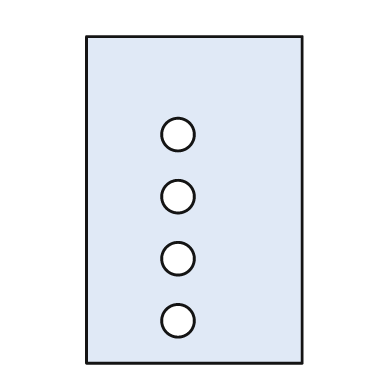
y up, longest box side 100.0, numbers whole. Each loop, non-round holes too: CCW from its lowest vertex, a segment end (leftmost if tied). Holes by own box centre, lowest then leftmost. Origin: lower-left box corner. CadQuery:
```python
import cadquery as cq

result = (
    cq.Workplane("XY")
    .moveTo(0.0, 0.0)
    .lineTo(66.0, 0.0)
    .lineTo(66.0, 100.0)
    .lineTo(0.0, 100.0)
    .close()
    .moveTo(28.0, 13.0)
    .circle(5.0)
    .moveTo(28.0, 32.0)
    .circle(5.0)
    .moveTo(28.0, 51.0)
    .circle(5.0)
    .moveTo(28.0, 70.0)
    .circle(5.0)
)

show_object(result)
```